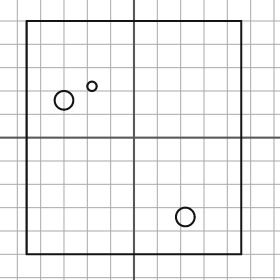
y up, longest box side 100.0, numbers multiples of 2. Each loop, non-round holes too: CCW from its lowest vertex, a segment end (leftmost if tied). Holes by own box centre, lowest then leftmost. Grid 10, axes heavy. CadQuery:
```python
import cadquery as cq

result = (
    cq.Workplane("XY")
    .moveTo(-46.0, -50.0)
    .lineTo(46.0, -50.0)
    .lineTo(46.0, 50.0)
    .lineTo(-46.0, 50.0)
    .close()
    .moveTo(22.0, -34.0)
    .circle(4.0)
    .moveTo(-30.0, 16.0)
    .circle(4.0)
    .moveTo(-18.0, 22.0)
    .circle(2.0)
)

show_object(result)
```